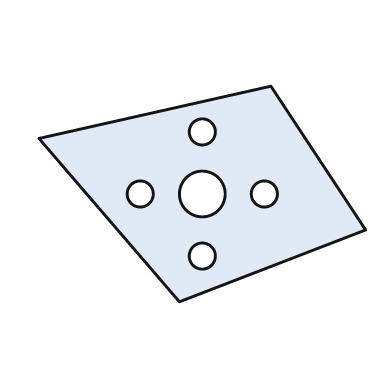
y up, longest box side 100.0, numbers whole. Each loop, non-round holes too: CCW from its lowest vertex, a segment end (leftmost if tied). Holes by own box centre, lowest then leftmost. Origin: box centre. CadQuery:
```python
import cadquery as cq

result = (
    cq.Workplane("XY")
    .moveTo(-7.0, -33.0)
    .lineTo(50.0, -11.0)
    .lineTo(21.0, 33.0)
    .lineTo(-50.0, 17.0)
    .close()
    .moveTo(0.0, -19.0)
    .circle(4.0)
    .moveTo(-19.0, 0.0)
    .circle(4.0)
    .moveTo(0.0, 0.0)
    .circle(7.0)
    .moveTo(19.0, 0.0)
    .circle(4.0)
    .moveTo(0.0, 19.0)
    .circle(4.0)
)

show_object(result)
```